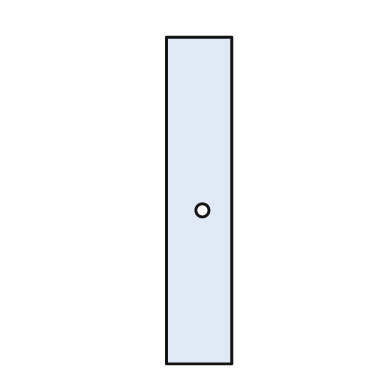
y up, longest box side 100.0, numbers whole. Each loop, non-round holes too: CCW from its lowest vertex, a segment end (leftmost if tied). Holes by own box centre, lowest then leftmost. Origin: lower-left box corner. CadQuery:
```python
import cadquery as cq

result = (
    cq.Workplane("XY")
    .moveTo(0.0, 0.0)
    .lineTo(20.0, 0.0)
    .lineTo(20.0, 100.0)
    .lineTo(0.0, 100.0)
    .close()
    .moveTo(11.0, 47.0)
    .circle(2.0)
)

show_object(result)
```